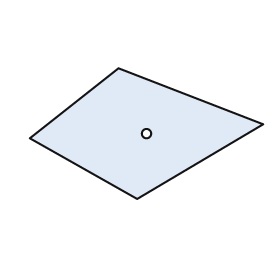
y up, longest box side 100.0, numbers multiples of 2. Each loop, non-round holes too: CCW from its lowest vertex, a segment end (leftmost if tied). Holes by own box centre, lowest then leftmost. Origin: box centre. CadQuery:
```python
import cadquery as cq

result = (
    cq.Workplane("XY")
    .moveTo(-4.0, -28.0)
    .lineTo(50.0, 4.0)
    .lineTo(-12.0, 28.0)
    .lineTo(-50.0, -2.0)
    .close()
    .moveTo(0.0, 0.0)
    .circle(2.0)
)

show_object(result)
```